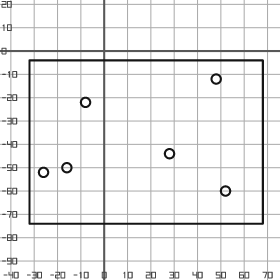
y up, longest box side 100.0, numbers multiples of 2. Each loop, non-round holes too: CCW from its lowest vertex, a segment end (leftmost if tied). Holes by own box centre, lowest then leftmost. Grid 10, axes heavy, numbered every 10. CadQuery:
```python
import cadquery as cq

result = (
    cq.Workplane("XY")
    .moveTo(-32.0, -74.0)
    .lineTo(68.0, -74.0)
    .lineTo(68.0, -4.0)
    .lineTo(-32.0, -4.0)
    .close()
    .moveTo(52.0, -60.0)
    .circle(2.0)
    .moveTo(-26.0, -52.0)
    .circle(2.0)
    .moveTo(-16.0, -50.0)
    .circle(2.0)
    .moveTo(28.0, -44.0)
    .circle(2.0)
    .moveTo(-8.0, -22.0)
    .circle(2.0)
    .moveTo(48.0, -12.0)
    .circle(2.0)
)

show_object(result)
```